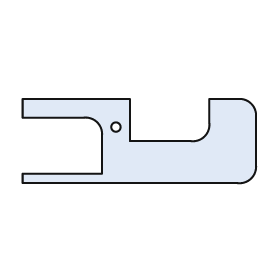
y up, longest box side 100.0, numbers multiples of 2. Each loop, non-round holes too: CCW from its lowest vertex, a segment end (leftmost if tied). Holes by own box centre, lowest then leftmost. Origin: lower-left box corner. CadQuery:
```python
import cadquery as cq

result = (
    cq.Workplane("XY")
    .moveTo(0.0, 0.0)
    .lineTo(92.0, 0.0)
    .threePointArc((98.0, 2.0), (100.0, 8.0))
    .lineTo(100.0, 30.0)
    .threePointArc((98.0, 34.0), (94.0, 36.0))
    .lineTo(80.0, 36.0)
    .lineTo(80.0, 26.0)
    .threePointArc((78.0, 20.0), (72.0, 18.0))
    .lineTo(46.0, 18.0)
    .lineTo(46.0, 36.0)
    .lineTo(0.0, 36.0)
    .lineTo(0.0, 28.0)
    .lineTo(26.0, 28.0)
    .threePointArc((32.0, 26.0), (34.0, 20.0))
    .lineTo(34.0, 4.0)
    .lineTo(0.0, 4.0)
    .close()
    .moveTo(40.0, 24.0)
    .circle(2.0)
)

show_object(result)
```